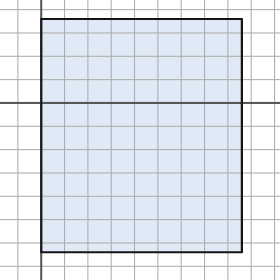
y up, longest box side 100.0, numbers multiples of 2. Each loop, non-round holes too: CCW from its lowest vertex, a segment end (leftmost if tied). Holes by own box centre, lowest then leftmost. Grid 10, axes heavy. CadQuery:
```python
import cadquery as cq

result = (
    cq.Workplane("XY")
    .moveTo(0.0, -64.0)
    .lineTo(86.0, -64.0)
    .lineTo(86.0, 36.0)
    .lineTo(0.0, 36.0)
    .close()
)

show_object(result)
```